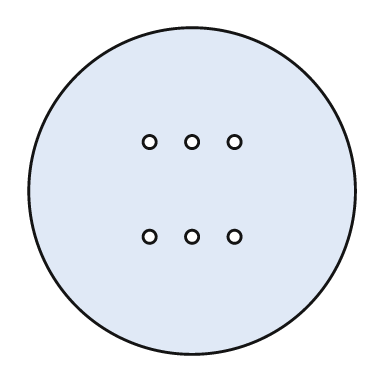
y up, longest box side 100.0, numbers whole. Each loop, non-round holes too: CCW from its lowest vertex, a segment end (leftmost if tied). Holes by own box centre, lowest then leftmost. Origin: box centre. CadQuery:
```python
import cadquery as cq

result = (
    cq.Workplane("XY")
    .moveTo(0.0, 0.0)
    .circle(50.0)
    .moveTo(-13.0, -14.0)
    .circle(2.0)
    .moveTo(0.0, -14.0)
    .circle(2.0)
    .moveTo(13.0, -14.0)
    .circle(2.0)
    .moveTo(-13.0, 15.0)
    .circle(2.0)
    .moveTo(0.0, 15.0)
    .circle(2.0)
    .moveTo(13.0, 15.0)
    .circle(2.0)
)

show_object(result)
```